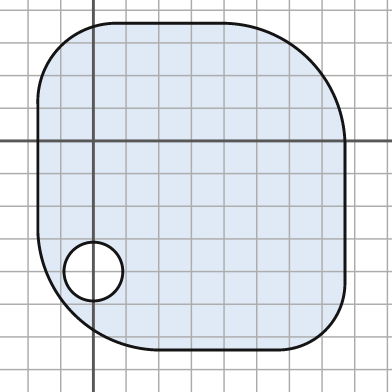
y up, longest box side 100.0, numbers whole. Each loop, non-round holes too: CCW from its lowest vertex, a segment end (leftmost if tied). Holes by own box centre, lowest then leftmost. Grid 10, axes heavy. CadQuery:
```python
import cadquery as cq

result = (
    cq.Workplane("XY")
    .moveTo(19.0, -64.0)
    .lineTo(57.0, -64.0)
    .threePointArc((71.0, -58.0), (77.0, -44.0))
    .lineTo(77.0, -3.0)
    .threePointArc((66.0, 25.0), (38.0, 36.0))
    .lineTo(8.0, 36.0)
    .threePointArc((-10.0, 29.0), (-17.0, 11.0))
    .lineTo(-17.0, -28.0)
    .threePointArc((-6.0, -53.0), (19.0, -64.0))
    .close()
    .moveTo(0.0, -40.0)
    .circle(9.0)
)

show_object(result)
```